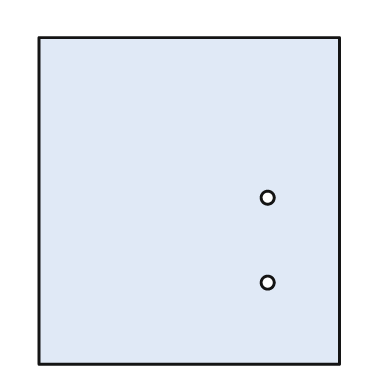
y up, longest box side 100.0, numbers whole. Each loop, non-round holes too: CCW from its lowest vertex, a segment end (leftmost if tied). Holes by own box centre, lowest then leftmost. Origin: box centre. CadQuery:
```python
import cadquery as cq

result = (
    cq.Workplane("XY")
    .moveTo(-46.0, -50.0)
    .lineTo(46.0, -50.0)
    .lineTo(46.0, 50.0)
    .lineTo(-46.0, 50.0)
    .close()
    .moveTo(24.0, -25.0)
    .circle(2.0)
    .moveTo(24.0, 1.0)
    .circle(2.0)
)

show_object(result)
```